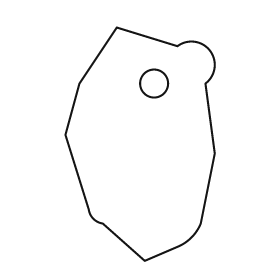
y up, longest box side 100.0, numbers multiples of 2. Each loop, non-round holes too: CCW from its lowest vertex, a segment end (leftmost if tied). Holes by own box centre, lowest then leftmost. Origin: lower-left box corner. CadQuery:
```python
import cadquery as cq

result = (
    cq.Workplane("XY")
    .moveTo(34.0, 0.0)
    .lineTo(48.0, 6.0)
    .threePointArc((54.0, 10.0), (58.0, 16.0))
    .lineTo(64.0, 46.0)
    .lineTo(60.0, 76.0)
    .threePointArc((62.0, 90.0), (48.0, 92.0))
    .lineTo(22.0, 100.0)
    .lineTo(6.0, 76.0)
    .lineTo(0.0, 54.0)
    .lineTo(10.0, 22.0)
    .threePointArc((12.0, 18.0), (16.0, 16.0))
    .close()
    .moveTo(38.0, 76.0)
    .circle(6.0)
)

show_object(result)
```